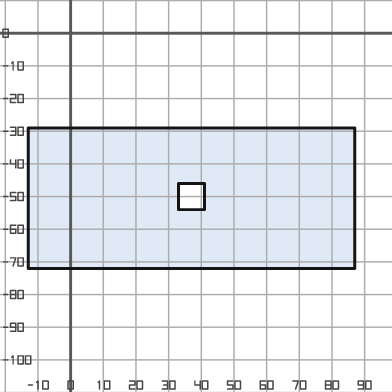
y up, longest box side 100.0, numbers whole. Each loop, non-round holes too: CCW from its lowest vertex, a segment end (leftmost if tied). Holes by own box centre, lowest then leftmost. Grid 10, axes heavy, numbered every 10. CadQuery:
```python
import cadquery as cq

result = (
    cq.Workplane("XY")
    .moveTo(-13.0, -72.0)
    .lineTo(87.0, -72.0)
    .lineTo(87.0, -29.0)
    .lineTo(-13.0, -29.0)
    .close()
    .moveTo(33.0, -54.0)
    .lineTo(41.0, -54.0)
    .lineTo(41.0, -46.0)
    .lineTo(33.0, -46.0)
    .close()
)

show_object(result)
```